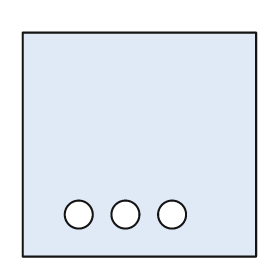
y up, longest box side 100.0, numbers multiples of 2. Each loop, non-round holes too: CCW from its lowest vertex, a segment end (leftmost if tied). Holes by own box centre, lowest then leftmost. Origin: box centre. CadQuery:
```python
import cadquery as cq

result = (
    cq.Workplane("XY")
    .moveTo(-50.0, -48.0)
    .lineTo(50.0, -48.0)
    .lineTo(50.0, 48.0)
    .lineTo(-50.0, 48.0)
    .close()
    .moveTo(-26.0, -30.0)
    .circle(6.0)
    .moveTo(-6.0, -30.0)
    .circle(6.0)
    .moveTo(14.0, -30.0)
    .circle(6.0)
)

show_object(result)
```